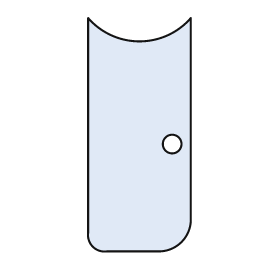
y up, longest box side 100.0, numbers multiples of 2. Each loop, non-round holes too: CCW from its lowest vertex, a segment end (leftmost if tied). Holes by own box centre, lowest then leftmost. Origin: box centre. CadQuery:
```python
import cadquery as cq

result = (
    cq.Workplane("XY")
    .moveTo(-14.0, -50.0)
    .lineTo(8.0, -50.0)
    .threePointArc((18.0, -46.0), (22.0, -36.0))
    .lineTo(22.0, 50.0)
    .threePointArc((0.0, 40.0), (-22.0, 50.0))
    .lineTo(-22.0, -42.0)
    .threePointArc((-20.0, -48.0), (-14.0, -50.0))
    .close()
    .moveTo(14.0, -4.0)
    .circle(4.0)
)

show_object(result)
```